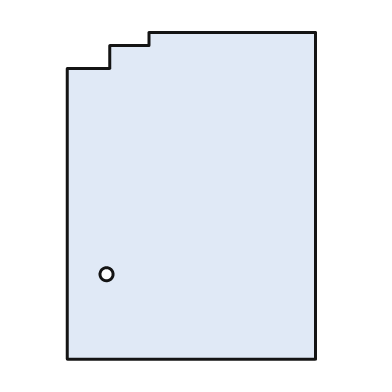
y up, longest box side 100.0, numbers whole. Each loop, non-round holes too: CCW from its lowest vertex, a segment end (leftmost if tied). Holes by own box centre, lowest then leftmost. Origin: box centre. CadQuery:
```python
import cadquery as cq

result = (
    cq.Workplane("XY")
    .moveTo(-38.0, -50.0)
    .lineTo(38.0, -50.0)
    .lineTo(38.0, 50.0)
    .lineTo(-13.0, 50.0)
    .lineTo(-13.0, 46.0)
    .lineTo(-25.0, 46.0)
    .lineTo(-25.0, 39.0)
    .lineTo(-38.0, 39.0)
    .close()
    .moveTo(-26.0, -24.0)
    .circle(2.0)
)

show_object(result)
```